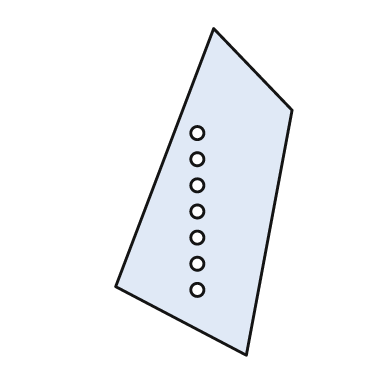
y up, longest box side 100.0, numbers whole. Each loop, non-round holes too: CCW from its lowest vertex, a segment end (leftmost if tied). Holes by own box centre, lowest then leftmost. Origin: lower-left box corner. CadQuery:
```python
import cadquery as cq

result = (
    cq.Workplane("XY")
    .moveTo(40.0, 0.0)
    .lineTo(54.0, 75.0)
    .lineTo(30.0, 100.0)
    .lineTo(0.0, 21.0)
    .close()
    .moveTo(25.0, 20.0)
    .circle(2.0)
    .moveTo(25.0, 28.0)
    .circle(2.0)
    .moveTo(25.0, 36.0)
    .circle(2.0)
    .moveTo(25.0, 44.0)
    .circle(2.0)
    .moveTo(25.0, 52.0)
    .circle(2.0)
    .moveTo(25.0, 60.0)
    .circle(2.0)
    .moveTo(25.0, 68.0)
    .circle(2.0)
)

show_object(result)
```